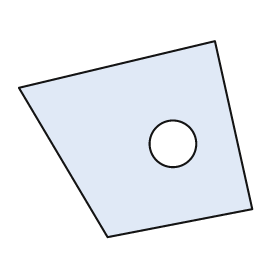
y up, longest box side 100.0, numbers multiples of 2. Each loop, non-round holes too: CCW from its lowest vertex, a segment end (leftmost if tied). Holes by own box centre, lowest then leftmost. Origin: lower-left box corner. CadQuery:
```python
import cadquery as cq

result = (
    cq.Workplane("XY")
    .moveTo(38.0, 0.0)
    .lineTo(100.0, 12.0)
    .lineTo(84.0, 84.0)
    .lineTo(0.0, 64.0)
    .close()
    .moveTo(66.0, 40.0)
    .circle(10.0)
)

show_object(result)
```